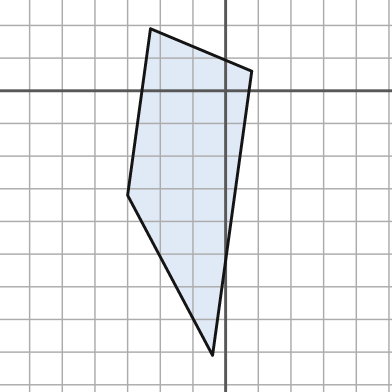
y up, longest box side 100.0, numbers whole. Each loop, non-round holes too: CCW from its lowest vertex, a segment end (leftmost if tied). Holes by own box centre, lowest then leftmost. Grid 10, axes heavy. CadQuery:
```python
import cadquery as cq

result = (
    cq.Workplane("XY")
    .moveTo(-4.0, -81.0)
    .lineTo(8.0, 6.0)
    .lineTo(-23.0, 19.0)
    .lineTo(-30.0, -32.0)
    .close()
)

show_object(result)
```